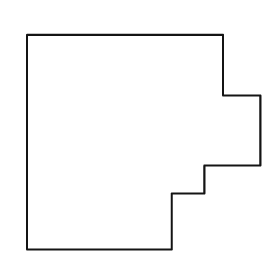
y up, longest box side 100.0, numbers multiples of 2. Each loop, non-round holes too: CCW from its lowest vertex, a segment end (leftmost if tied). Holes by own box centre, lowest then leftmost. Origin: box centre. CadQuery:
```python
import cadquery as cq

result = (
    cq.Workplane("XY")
    .moveTo(-50.0, -46.0)
    .lineTo(12.0, -46.0)
    .lineTo(12.0, -22.0)
    .lineTo(26.0, -22.0)
    .lineTo(26.0, -10.0)
    .lineTo(50.0, -10.0)
    .lineTo(50.0, 20.0)
    .lineTo(34.0, 20.0)
    .lineTo(34.0, 46.0)
    .lineTo(-50.0, 46.0)
    .close()
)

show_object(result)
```